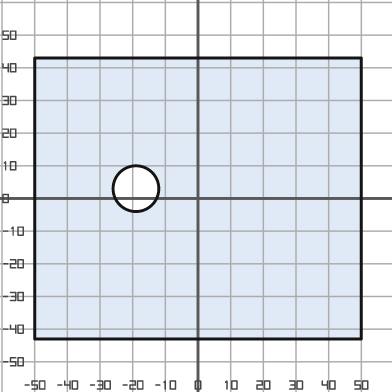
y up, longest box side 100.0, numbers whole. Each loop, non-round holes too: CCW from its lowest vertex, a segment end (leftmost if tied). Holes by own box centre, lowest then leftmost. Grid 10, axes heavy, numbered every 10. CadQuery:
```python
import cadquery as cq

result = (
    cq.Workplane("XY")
    .moveTo(-50.0, -43.0)
    .lineTo(50.0, -43.0)
    .lineTo(50.0, 43.0)
    .lineTo(-50.0, 43.0)
    .close()
    .moveTo(-19.0, 3.0)
    .circle(7.0)
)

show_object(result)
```